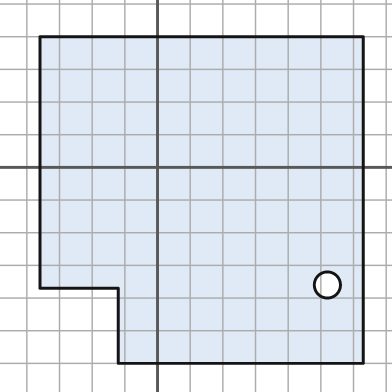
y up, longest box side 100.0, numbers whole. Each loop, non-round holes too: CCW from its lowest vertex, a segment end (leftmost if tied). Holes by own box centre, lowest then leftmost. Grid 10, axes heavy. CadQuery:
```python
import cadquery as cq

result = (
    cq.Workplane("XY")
    .moveTo(-12.0, -60.0)
    .lineTo(63.0, -60.0)
    .lineTo(63.0, 40.0)
    .lineTo(-36.0, 40.0)
    .lineTo(-36.0, -37.0)
    .lineTo(-12.0, -37.0)
    .close()
    .moveTo(52.0, -36.0)
    .circle(4.0)
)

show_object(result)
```